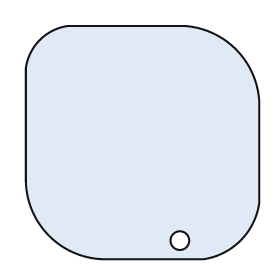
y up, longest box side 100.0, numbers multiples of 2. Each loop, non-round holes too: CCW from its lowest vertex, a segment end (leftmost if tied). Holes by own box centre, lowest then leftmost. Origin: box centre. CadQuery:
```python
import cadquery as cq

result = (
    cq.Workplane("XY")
    .moveTo(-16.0, -50.0)
    .lineTo(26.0, -50.0)
    .threePointArc((42.0, -42.0), (50.0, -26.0))
    .lineTo(50.0, 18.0)
    .threePointArc((40.0, 40.0), (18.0, 50.0))
    .lineTo(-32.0, 50.0)
    .threePointArc((-44.0, 44.0), (-50.0, 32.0))
    .lineTo(-50.0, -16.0)
    .threePointArc((-40.0, -40.0), (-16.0, -50.0))
    .close()
    .moveTo(16.0, -42.0)
    .circle(4.0)
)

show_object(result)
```